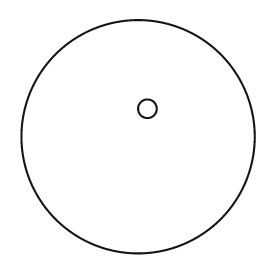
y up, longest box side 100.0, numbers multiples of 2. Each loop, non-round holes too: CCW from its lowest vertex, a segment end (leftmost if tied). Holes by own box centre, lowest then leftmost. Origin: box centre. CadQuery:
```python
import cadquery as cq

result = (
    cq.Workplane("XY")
    .moveTo(0.0, 0.0)
    .circle(50.0)
    .moveTo(4.0, 12.0)
    .circle(4.0)
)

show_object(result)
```